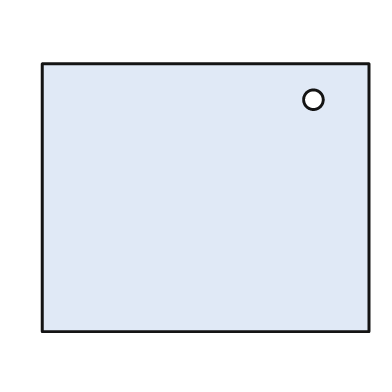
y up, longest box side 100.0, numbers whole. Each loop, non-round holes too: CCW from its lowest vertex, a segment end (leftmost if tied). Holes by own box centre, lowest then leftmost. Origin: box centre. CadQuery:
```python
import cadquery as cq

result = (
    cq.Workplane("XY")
    .moveTo(-50.0, -41.0)
    .lineTo(50.0, -41.0)
    .lineTo(50.0, 41.0)
    .lineTo(-50.0, 41.0)
    .close()
    .moveTo(33.0, 30.0)
    .circle(3.0)
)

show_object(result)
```